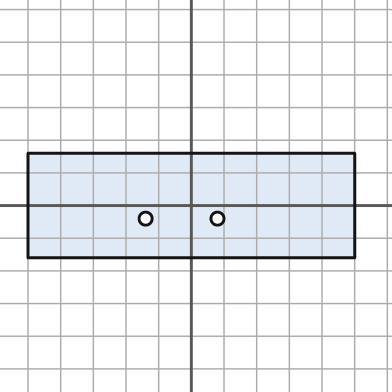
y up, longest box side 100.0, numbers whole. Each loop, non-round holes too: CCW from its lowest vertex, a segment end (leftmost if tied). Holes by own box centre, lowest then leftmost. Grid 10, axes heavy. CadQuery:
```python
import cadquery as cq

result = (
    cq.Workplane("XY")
    .moveTo(-50.0, -16.0)
    .lineTo(50.0, -16.0)
    .lineTo(50.0, 16.0)
    .lineTo(-50.0, 16.0)
    .close()
    .moveTo(-14.0, -4.0)
    .circle(2.0)
    .moveTo(8.0, -4.0)
    .circle(2.0)
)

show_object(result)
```